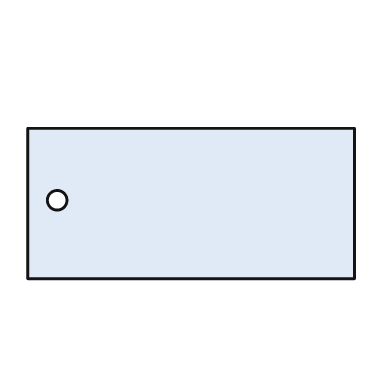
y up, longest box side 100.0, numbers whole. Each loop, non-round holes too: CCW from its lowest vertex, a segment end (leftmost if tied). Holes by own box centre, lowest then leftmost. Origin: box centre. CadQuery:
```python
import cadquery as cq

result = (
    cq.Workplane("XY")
    .moveTo(-50.0, -23.0)
    .lineTo(50.0, -23.0)
    .lineTo(50.0, 23.0)
    .lineTo(-50.0, 23.0)
    .close()
    .moveTo(-41.0, 1.0)
    .circle(3.0)
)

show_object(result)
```